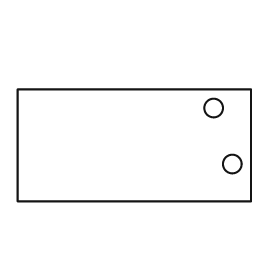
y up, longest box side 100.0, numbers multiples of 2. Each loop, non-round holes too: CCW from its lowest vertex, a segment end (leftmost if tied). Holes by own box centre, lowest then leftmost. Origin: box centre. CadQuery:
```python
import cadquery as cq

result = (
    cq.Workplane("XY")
    .moveTo(-50.0, -24.0)
    .lineTo(50.0, -24.0)
    .lineTo(50.0, 24.0)
    .lineTo(-50.0, 24.0)
    .close()
    .moveTo(42.0, -8.0)
    .circle(4.0)
    .moveTo(34.0, 16.0)
    .circle(4.0)
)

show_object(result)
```